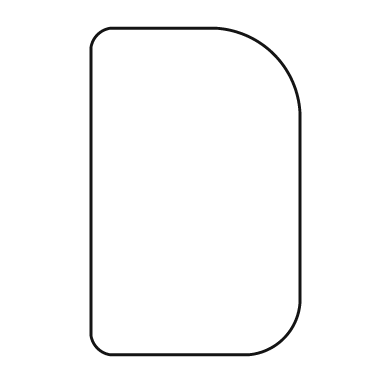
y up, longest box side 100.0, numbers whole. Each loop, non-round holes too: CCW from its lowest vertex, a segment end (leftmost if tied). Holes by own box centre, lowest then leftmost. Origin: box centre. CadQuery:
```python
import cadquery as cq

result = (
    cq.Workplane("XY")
    .moveTo(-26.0, -50.0)
    .lineTo(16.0, -50.0)
    .threePointArc((27.0, -45.0), (32.0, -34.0))
    .lineTo(32.0, 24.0)
    .threePointArc((24.0, 42.0), (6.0, 50.0))
    .lineTo(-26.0, 50.0)
    .threePointArc((-30.0, 48.0), (-32.0, 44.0))
    .lineTo(-32.0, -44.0)
    .threePointArc((-30.0, -48.0), (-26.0, -50.0))
    .close()
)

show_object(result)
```